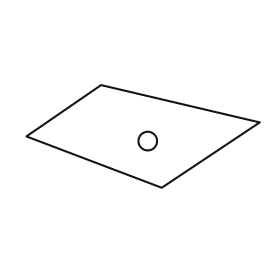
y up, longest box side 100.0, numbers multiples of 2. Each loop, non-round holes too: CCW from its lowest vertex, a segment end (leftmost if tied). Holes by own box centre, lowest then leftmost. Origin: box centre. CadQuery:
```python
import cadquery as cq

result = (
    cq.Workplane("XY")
    .moveTo(8.0, -22.0)
    .lineTo(50.0, 6.0)
    .lineTo(-18.0, 22.0)
    .lineTo(-50.0, 0.0)
    .close()
    .moveTo(2.0, -2.0)
    .circle(4.0)
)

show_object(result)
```